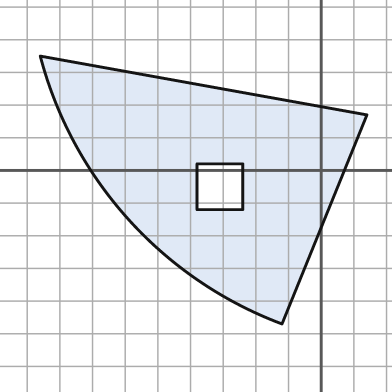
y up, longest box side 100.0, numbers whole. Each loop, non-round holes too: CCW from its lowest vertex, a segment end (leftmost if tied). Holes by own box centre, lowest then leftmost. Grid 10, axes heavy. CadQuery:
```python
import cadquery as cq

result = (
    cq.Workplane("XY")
    .moveTo(-12.0, -47.0)
    .lineTo(14.0, 17.0)
    .lineTo(-86.0, 35.0)
    .threePointArc((-59.0, -15.0), (-12.0, -47.0))
    .close()
    .moveTo(-38.0, -12.0)
    .lineTo(-24.0, -12.0)
    .lineTo(-24.0, 2.0)
    .lineTo(-38.0, 2.0)
    .close()
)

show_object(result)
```